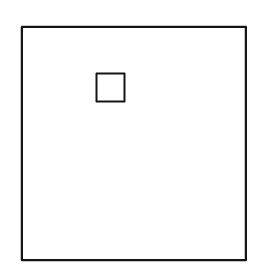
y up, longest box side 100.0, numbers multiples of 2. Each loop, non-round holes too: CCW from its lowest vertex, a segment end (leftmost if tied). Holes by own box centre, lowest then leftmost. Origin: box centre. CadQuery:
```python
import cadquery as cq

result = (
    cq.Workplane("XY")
    .moveTo(-48.0, -50.0)
    .lineTo(48.0, -50.0)
    .lineTo(48.0, 50.0)
    .lineTo(-48.0, 50.0)
    .close()
    .moveTo(-16.0, 18.0)
    .lineTo(-4.0, 18.0)
    .lineTo(-4.0, 30.0)
    .lineTo(-16.0, 30.0)
    .close()
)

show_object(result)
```